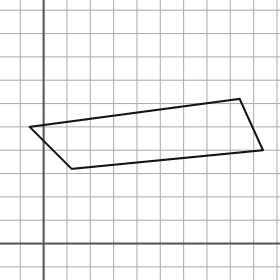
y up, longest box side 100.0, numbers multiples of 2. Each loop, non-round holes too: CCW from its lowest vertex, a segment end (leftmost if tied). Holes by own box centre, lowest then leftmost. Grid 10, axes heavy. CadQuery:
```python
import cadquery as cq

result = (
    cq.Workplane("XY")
    .moveTo(12.0, 32.0)
    .lineTo(94.0, 40.0)
    .lineTo(84.0, 62.0)
    .lineTo(-6.0, 50.0)
    .close()
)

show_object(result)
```